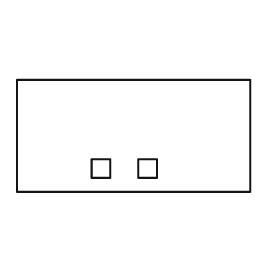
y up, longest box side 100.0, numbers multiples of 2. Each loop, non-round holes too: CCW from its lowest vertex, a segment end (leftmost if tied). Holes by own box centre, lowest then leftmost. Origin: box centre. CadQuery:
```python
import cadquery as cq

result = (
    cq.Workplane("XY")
    .moveTo(-50.0, -24.0)
    .lineTo(50.0, -24.0)
    .lineTo(50.0, 24.0)
    .lineTo(-50.0, 24.0)
    .close()
    .moveTo(-18.0, -18.0)
    .lineTo(-10.0, -18.0)
    .lineTo(-10.0, -10.0)
    .lineTo(-18.0, -10.0)
    .close()
    .moveTo(2.0, -18.0)
    .lineTo(10.0, -18.0)
    .lineTo(10.0, -10.0)
    .lineTo(2.0, -10.0)
    .close()
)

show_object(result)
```